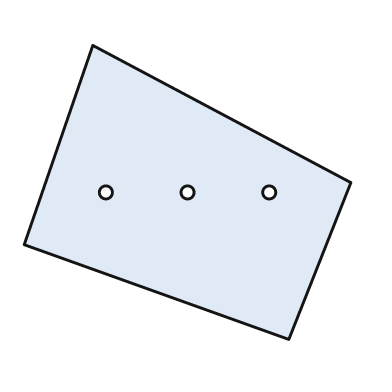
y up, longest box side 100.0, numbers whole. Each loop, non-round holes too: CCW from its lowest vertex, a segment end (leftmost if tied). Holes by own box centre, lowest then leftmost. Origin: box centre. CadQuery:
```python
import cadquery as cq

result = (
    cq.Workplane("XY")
    .moveTo(31.0, -45.0)
    .lineTo(50.0, 3.0)
    .lineTo(-29.0, 45.0)
    .lineTo(-50.0, -16.0)
    .close()
    .moveTo(-25.0, 0.0)
    .circle(2.0)
    .moveTo(0.0, 0.0)
    .circle(2.0)
    .moveTo(25.0, 0.0)
    .circle(2.0)
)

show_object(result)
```